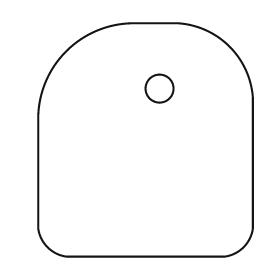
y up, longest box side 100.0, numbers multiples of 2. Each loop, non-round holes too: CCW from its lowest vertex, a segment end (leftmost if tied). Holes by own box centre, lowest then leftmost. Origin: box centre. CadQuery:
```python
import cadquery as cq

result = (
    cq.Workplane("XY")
    .moveTo(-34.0, -50.0)
    .lineTo(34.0, -50.0)
    .threePointArc((42.0, -46.0), (46.0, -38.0))
    .lineTo(46.0, 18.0)
    .threePointArc((36.0, 40.0), (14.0, 50.0))
    .lineTo(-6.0, 50.0)
    .threePointArc((-34.0, 38.0), (-46.0, 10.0))
    .lineTo(-46.0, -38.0)
    .threePointArc((-42.0, -46.0), (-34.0, -50.0))
    .close()
    .moveTo(6.0, 22.0)
    .circle(6.0)
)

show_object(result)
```